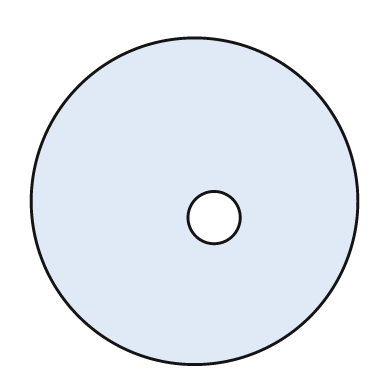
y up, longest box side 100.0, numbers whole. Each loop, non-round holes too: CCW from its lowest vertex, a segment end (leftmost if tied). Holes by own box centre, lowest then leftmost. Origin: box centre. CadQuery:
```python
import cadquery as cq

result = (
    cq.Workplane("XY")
    .moveTo(0.0, 0.0)
    .circle(50.0)
    .moveTo(6.0, -5.0)
    .circle(8.0)
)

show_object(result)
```